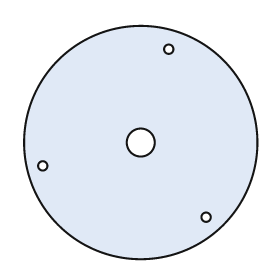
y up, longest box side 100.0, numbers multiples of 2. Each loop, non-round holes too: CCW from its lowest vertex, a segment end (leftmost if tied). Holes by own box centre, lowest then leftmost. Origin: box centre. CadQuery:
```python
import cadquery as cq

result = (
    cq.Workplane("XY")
    .moveTo(0.0, 0.0)
    .circle(50.0)
    .moveTo(28.0, -32.0)
    .circle(2.0)
    .moveTo(-42.0, -10.0)
    .circle(2.0)
    .moveTo(0.0, 0.0)
    .circle(6.0)
    .moveTo(12.0, 40.0)
    .circle(2.0)
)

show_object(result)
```